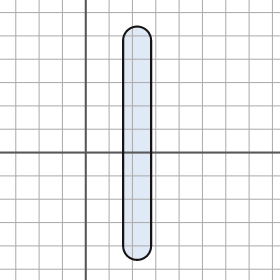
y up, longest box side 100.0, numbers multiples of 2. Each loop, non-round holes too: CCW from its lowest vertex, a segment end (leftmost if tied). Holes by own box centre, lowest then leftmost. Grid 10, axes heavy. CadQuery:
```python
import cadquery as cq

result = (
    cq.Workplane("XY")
    .moveTo(16.0, -40.0)
    .threePointArc((22.0, -46.0), (28.0, -40.0))
    .lineTo(28.0, 48.0)
    .threePointArc((22.0, 54.0), (16.0, 48.0))
    .close()
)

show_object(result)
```